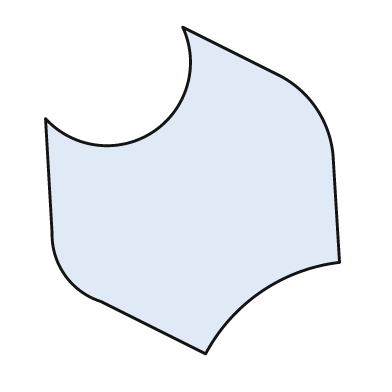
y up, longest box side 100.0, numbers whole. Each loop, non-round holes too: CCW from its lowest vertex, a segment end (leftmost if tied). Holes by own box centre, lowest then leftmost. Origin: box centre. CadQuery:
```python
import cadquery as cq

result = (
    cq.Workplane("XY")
    .moveTo(4.0, -50.0)
    .threePointArc((21.0, -31.0), (45.0, -22.0))
    .lineTo(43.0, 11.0)
    .threePointArc((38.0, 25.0), (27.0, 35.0))
    .lineTo(-3.0, 50.0)
    .threePointArc((-12.0, 18.0), (-45.0, 22.0))
    .lineTo(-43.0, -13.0)
    .threePointArc((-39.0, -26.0), (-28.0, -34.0))
    .close()
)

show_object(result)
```